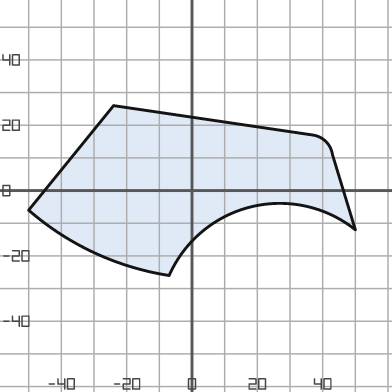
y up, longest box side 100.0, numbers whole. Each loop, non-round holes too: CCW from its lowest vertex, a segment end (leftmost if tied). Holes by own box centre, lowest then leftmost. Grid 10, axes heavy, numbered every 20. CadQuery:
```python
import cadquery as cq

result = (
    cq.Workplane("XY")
    .moveTo(-7.0, -26.0)
    .threePointArc((18.0, -5.0), (50.0, -12.0))
    .lineTo(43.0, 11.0)
    .threePointArc((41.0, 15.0), (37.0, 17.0))
    .lineTo(-24.0, 26.0)
    .lineTo(-50.0, -6.0)
    .threePointArc((-30.0, -19.0), (-7.0, -26.0))
    .close()
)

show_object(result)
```